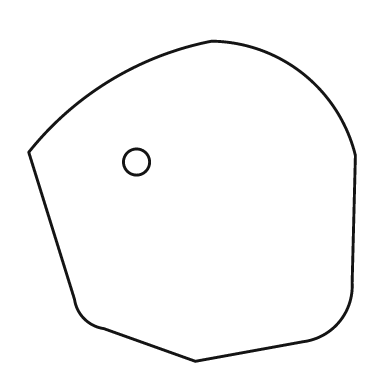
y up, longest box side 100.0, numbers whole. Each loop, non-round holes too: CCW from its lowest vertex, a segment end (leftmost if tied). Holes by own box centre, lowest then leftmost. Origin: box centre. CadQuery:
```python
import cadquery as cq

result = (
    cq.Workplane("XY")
    .moveTo(1.0, -49.0)
    .lineTo(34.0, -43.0)
    .threePointArc((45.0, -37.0), (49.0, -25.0))
    .lineTo(50.0, 14.0)
    .threePointArc((34.0, 39.0), (6.0, 49.0))
    .threePointArc((-25.0, 37.0), (-50.0, 15.0))
    .lineTo(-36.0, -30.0)
    .threePointArc((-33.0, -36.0), (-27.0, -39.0))
    .close()
    .moveTo(-17.0, 12.0)
    .circle(4.0)
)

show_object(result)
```